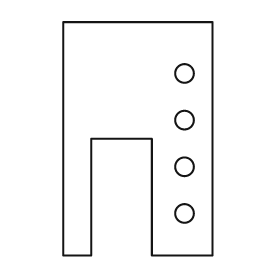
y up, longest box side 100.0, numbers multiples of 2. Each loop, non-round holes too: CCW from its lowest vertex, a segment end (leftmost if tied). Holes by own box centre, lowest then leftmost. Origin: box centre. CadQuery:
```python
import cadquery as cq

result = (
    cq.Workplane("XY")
    .moveTo(-32.0, -50.0)
    .lineTo(-20.0, -50.0)
    .lineTo(-20.0, 0.0)
    .lineTo(6.0, 0.0)
    .lineTo(6.0, -50.0)
    .lineTo(32.0, -50.0)
    .lineTo(32.0, 50.0)
    .lineTo(-32.0, 50.0)
    .close()
    .moveTo(20.0, -32.0)
    .circle(4.0)
    .moveTo(20.0, -12.0)
    .circle(4.0)
    .moveTo(20.0, 8.0)
    .circle(4.0)
    .moveTo(20.0, 28.0)
    .circle(4.0)
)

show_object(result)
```